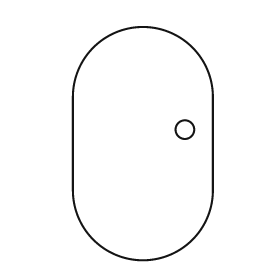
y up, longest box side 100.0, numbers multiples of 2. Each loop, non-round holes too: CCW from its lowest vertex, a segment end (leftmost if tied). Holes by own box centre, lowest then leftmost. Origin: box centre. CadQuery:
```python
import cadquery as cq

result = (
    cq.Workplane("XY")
    .moveTo(-30.0, -20.0)
    .threePointArc((0.0, -50.0), (30.0, -20.0))
    .lineTo(30.0, 20.0)
    .threePointArc((0.0, 50.0), (-30.0, 20.0))
    .close()
    .moveTo(18.0, 6.0)
    .circle(4.0)
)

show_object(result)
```